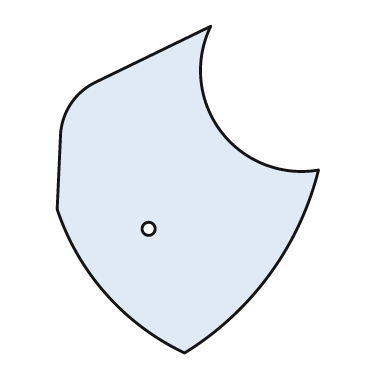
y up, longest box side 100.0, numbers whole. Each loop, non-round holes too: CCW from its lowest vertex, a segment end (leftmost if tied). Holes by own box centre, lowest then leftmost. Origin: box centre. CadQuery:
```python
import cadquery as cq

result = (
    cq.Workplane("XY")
    .moveTo(-1.0, -50.0)
    .threePointArc((25.0, -26.0), (40.0, 6.0))
    .threePointArc((10.0, 18.0), (7.0, 50.0))
    .lineTo(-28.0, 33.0)
    .threePointArc((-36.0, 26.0), (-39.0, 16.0))
    .lineTo(-40.0, -6.0)
    .threePointArc((-25.0, -32.0), (-1.0, -50.0))
    .close()
    .moveTo(-12.0, -12.0)
    .circle(2.0)
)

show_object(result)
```